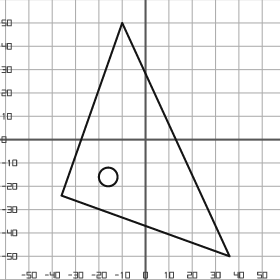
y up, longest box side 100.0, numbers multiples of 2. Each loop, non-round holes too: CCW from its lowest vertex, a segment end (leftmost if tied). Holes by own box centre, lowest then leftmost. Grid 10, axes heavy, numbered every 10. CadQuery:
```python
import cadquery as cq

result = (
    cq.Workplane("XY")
    .moveTo(36.0, -50.0)
    .lineTo(-10.0, 50.0)
    .lineTo(-36.0, -24.0)
    .close()
    .moveTo(-16.0, -16.0)
    .circle(4.0)
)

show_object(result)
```